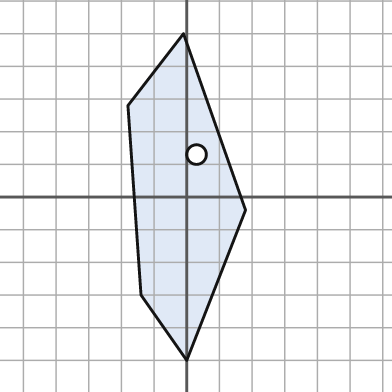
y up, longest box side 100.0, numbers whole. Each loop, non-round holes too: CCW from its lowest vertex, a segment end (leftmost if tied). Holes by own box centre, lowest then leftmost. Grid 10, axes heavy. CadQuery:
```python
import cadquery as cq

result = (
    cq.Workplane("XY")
    .moveTo(0.0, -50.0)
    .lineTo(18.0, -4.0)
    .lineTo(-1.0, 50.0)
    .lineTo(-18.0, 28.0)
    .lineTo(-14.0, -30.0)
    .close()
    .moveTo(3.0, 13.0)
    .circle(3.0)
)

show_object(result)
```